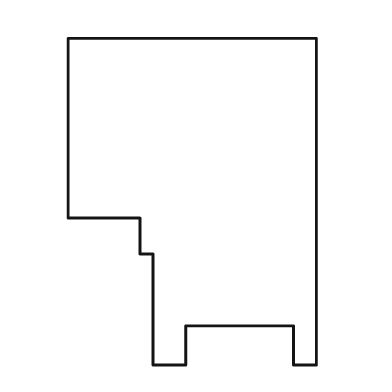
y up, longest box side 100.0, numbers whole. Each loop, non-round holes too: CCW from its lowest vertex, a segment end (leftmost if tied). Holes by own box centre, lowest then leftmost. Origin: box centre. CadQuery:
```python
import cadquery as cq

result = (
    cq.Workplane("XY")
    .moveTo(-12.0, -50.0)
    .lineTo(-2.0, -50.0)
    .lineTo(-2.0, -38.0)
    .lineTo(31.0, -38.0)
    .lineTo(31.0, -50.0)
    .lineTo(38.0, -50.0)
    .lineTo(38.0, 50.0)
    .lineTo(-38.0, 50.0)
    .lineTo(-38.0, -5.0)
    .lineTo(-16.0, -5.0)
    .lineTo(-16.0, -16.0)
    .lineTo(-12.0, -16.0)
    .close()
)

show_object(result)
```